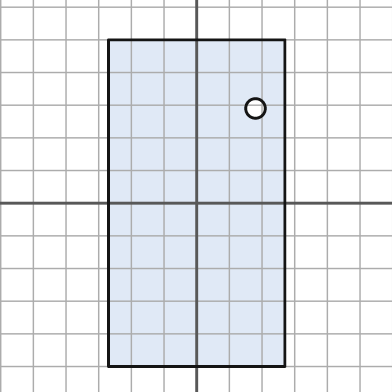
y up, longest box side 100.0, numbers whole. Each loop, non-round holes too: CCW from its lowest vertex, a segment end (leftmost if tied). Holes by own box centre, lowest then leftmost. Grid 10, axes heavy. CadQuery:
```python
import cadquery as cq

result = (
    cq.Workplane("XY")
    .moveTo(-27.0, -50.0)
    .lineTo(27.0, -50.0)
    .lineTo(27.0, 50.0)
    .lineTo(-27.0, 50.0)
    .close()
    .moveTo(18.0, 29.0)
    .circle(3.0)
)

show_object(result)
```